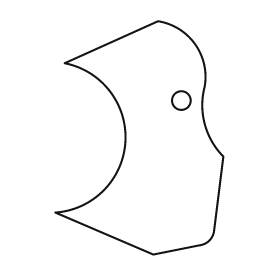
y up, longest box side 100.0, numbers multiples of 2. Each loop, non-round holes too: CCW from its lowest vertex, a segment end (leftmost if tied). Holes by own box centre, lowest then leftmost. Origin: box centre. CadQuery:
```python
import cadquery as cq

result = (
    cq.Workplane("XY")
    .moveTo(6.0, -50.0)
    .lineTo(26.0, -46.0)
    .threePointArc((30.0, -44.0), (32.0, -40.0))
    .lineTo(36.0, -8.0)
    .threePointArc((28.0, 6.0), (28.0, 22.0))
    .threePointArc((24.0, 40.0), (8.0, 50.0))
    .lineTo(-32.0, 32.0)
    .threePointArc((-6.0, -2.0), (-36.0, -32.0))
    .close()
    .moveTo(18.0, 16.0)
    .circle(4.0)
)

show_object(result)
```